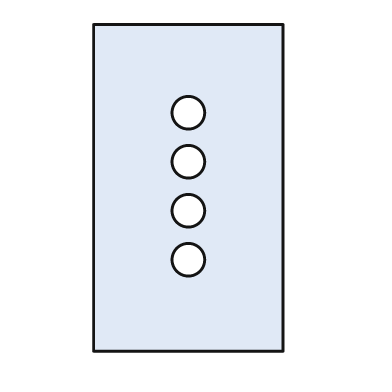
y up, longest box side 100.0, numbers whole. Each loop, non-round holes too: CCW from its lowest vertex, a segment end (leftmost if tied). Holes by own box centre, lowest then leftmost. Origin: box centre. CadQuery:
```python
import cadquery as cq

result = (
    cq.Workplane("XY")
    .moveTo(-29.0, -50.0)
    .lineTo(29.0, -50.0)
    .lineTo(29.0, 50.0)
    .lineTo(-29.0, 50.0)
    .close()
    .moveTo(0.0, -22.0)
    .circle(5.0)
    .moveTo(0.0, -7.0)
    .circle(5.0)
    .moveTo(0.0, 8.0)
    .circle(5.0)
    .moveTo(0.0, 23.0)
    .circle(5.0)
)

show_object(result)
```